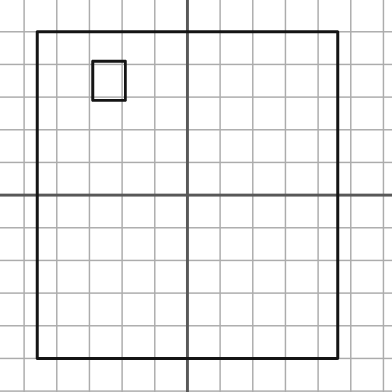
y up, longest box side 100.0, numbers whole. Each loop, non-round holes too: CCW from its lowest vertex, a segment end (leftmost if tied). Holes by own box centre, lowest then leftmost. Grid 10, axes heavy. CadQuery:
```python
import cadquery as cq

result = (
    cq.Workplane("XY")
    .moveTo(-46.0, -50.0)
    .lineTo(46.0, -50.0)
    .lineTo(46.0, 50.0)
    .lineTo(-46.0, 50.0)
    .close()
    .moveTo(-29.0, 29.0)
    .lineTo(-19.0, 29.0)
    .lineTo(-19.0, 41.0)
    .lineTo(-29.0, 41.0)
    .close()
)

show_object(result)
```